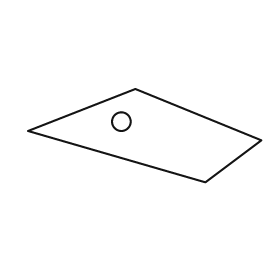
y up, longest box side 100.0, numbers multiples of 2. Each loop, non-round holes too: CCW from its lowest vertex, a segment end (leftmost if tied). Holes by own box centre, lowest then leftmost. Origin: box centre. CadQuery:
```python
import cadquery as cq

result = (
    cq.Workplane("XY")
    .moveTo(26.0, -20.0)
    .lineTo(50.0, -2.0)
    .lineTo(-4.0, 20.0)
    .lineTo(-50.0, 2.0)
    .close()
    .moveTo(-10.0, 6.0)
    .circle(4.0)
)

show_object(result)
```